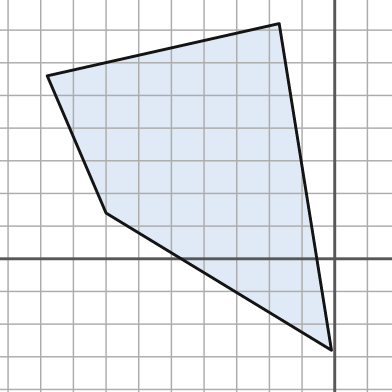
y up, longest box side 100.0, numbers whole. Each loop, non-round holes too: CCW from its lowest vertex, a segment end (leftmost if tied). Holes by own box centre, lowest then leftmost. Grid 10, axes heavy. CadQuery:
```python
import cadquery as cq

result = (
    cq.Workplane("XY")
    .moveTo(-1.0, -28.0)
    .lineTo(-17.0, 72.0)
    .lineTo(-88.0, 56.0)
    .lineTo(-70.0, 14.0)
    .close()
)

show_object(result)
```